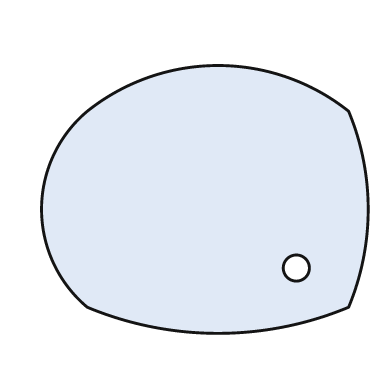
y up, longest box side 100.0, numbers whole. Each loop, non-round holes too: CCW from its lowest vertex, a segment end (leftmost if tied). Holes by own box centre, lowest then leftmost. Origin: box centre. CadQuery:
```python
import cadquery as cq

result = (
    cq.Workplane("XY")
    .moveTo(-36.0, -33.0)
    .threePointArc((4.0, -41.0), (44.0, -33.0))
    .threePointArc((50.0, -3.0), (44.0, 27.0))
    .threePointArc((4.0, 41.0), (-36.0, 27.0))
    .threePointArc((-50.0, -3.0), (-36.0, -33.0))
    .close()
    .moveTo(28.0, -21.0)
    .circle(4.0)
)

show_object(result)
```